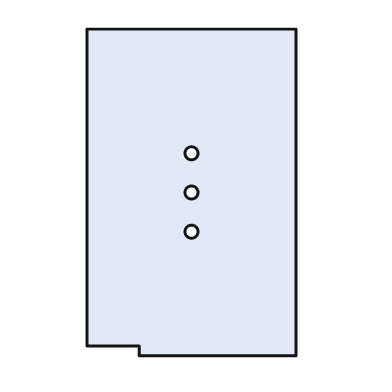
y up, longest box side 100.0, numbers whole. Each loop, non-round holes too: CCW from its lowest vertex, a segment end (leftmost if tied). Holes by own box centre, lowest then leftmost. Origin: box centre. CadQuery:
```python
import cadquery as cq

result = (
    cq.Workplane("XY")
    .moveTo(-16.0, -50.0)
    .lineTo(32.0, -50.0)
    .lineTo(32.0, 50.0)
    .lineTo(-32.0, 50.0)
    .lineTo(-32.0, -47.0)
    .lineTo(-16.0, -47.0)
    .close()
    .moveTo(0.0, -12.0)
    .circle(2.0)
    .moveTo(0.0, 0.0)
    .circle(2.0)
    .moveTo(0.0, 12.0)
    .circle(2.0)
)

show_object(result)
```